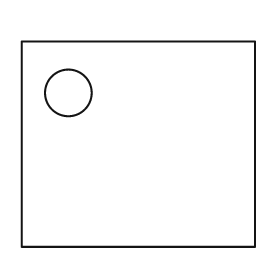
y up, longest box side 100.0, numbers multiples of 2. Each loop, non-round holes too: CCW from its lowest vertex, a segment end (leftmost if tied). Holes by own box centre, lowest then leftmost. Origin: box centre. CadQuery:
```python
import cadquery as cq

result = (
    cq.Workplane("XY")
    .moveTo(-50.0, -44.0)
    .lineTo(50.0, -44.0)
    .lineTo(50.0, 44.0)
    .lineTo(-50.0, 44.0)
    .close()
    .moveTo(-30.0, 22.0)
    .circle(10.0)
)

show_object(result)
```